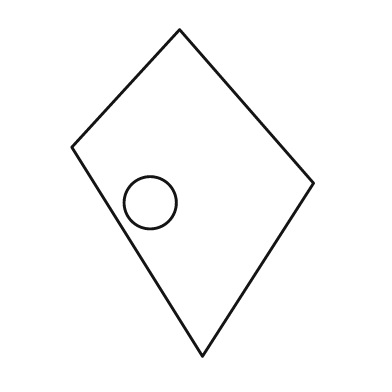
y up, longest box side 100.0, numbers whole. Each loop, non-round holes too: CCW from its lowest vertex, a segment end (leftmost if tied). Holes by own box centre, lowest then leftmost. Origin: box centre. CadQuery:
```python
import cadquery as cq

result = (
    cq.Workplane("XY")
    .moveTo(3.0, -50.0)
    .lineTo(37.0, 3.0)
    .lineTo(-4.0, 50.0)
    .lineTo(-37.0, 14.0)
    .close()
    .moveTo(-13.0, -3.0)
    .circle(8.0)
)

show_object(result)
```